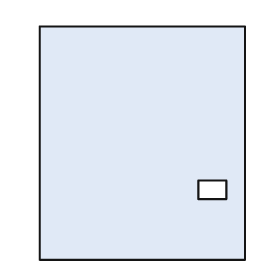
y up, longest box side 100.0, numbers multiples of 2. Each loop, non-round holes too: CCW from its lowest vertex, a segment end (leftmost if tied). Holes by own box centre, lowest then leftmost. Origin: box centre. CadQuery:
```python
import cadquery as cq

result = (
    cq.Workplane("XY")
    .moveTo(-44.0, -50.0)
    .lineTo(44.0, -50.0)
    .lineTo(44.0, 50.0)
    .lineTo(-44.0, 50.0)
    .close()
    .moveTo(24.0, -24.0)
    .lineTo(36.0, -24.0)
    .lineTo(36.0, -16.0)
    .lineTo(24.0, -16.0)
    .close()
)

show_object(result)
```